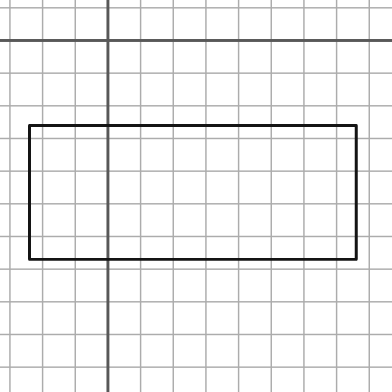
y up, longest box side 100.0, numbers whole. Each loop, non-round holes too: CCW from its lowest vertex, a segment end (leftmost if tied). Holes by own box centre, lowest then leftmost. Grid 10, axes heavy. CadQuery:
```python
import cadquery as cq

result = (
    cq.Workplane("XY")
    .moveTo(-24.0, -67.0)
    .lineTo(76.0, -67.0)
    .lineTo(76.0, -26.0)
    .lineTo(-24.0, -26.0)
    .close()
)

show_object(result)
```